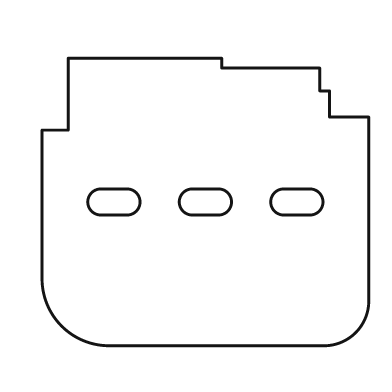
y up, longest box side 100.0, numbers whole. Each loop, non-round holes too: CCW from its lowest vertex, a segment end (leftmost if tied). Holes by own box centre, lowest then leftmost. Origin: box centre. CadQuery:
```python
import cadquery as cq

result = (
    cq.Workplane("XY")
    .moveTo(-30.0, -44.0)
    .lineTo(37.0, -44.0)
    .threePointArc((46.0, -40.0), (50.0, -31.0))
    .lineTo(50.0, 26.0)
    .lineTo(38.0, 26.0)
    .lineTo(38.0, 34.0)
    .lineTo(35.0, 34.0)
    .lineTo(35.0, 41.0)
    .lineTo(5.0, 41.0)
    .lineTo(5.0, 44.0)
    .lineTo(-42.0, 44.0)
    .lineTo(-42.0, 22.0)
    .lineTo(-50.0, 22.0)
    .lineTo(-50.0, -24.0)
    .threePointArc((-44.0, -38.0), (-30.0, -44.0))
    .close()
    .moveTo(-32.0, -4.0)
    .lineTo(-24.0, -4.0)
    .threePointArc((-20.0, 0.0), (-24.0, 4.0))
    .lineTo(-32.0, 4.0)
    .threePointArc((-36.0, 0.0), (-32.0, -4.0))
    .close()
    .moveTo(-4.0, -4.0)
    .lineTo(4.0, -4.0)
    .threePointArc((8.0, 0.0), (4.0, 4.0))
    .lineTo(-4.0, 4.0)
    .threePointArc((-8.0, 0.0), (-4.0, -4.0))
    .close()
    .moveTo(24.0, -4.0)
    .lineTo(32.0, -4.0)
    .threePointArc((36.0, 0.0), (32.0, 4.0))
    .lineTo(24.0, 4.0)
    .threePointArc((20.0, 0.0), (24.0, -4.0))
    .close()
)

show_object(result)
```